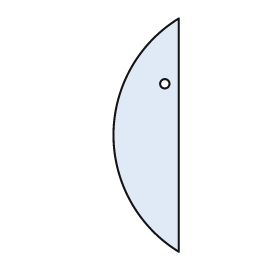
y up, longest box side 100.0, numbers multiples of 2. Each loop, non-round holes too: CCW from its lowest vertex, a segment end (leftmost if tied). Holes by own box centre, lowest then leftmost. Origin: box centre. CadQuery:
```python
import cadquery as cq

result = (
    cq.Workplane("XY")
    .moveTo(14.0, -50.0)
    .lineTo(14.0, 50.0)
    .threePointArc((-14.0, 0.0), (14.0, -50.0))
    .close()
    .moveTo(8.0, 22.0)
    .circle(2.0)
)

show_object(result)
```